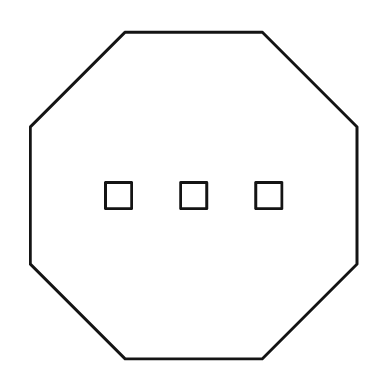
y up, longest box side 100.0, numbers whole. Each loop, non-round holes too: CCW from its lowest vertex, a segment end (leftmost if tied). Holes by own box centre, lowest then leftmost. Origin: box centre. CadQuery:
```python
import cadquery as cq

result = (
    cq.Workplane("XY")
    .moveTo(-21.0, -50.0)
    .lineTo(21.0, -50.0)
    .lineTo(50.0, -21.0)
    .lineTo(50.0, 21.0)
    .lineTo(21.0, 50.0)
    .lineTo(-21.0, 50.0)
    .lineTo(-50.0, 21.0)
    .lineTo(-50.0, -21.0)
    .close()
    .moveTo(-27.0, -4.0)
    .lineTo(-19.0, -4.0)
    .lineTo(-19.0, 4.0)
    .lineTo(-27.0, 4.0)
    .close()
    .moveTo(-4.0, -4.0)
    .lineTo(4.0, -4.0)
    .lineTo(4.0, 4.0)
    .lineTo(-4.0, 4.0)
    .close()
    .moveTo(19.0, -4.0)
    .lineTo(27.0, -4.0)
    .lineTo(27.0, 4.0)
    .lineTo(19.0, 4.0)
    .close()
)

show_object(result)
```